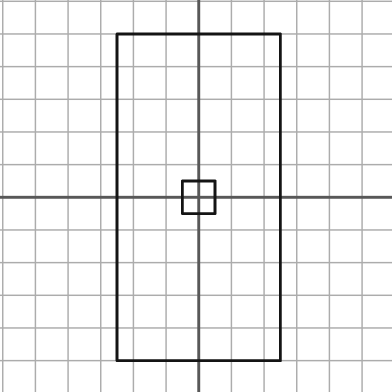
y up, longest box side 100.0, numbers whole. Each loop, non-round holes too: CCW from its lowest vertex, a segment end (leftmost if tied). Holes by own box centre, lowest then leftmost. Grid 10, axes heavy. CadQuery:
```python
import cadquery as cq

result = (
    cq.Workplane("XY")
    .moveTo(-25.0, -50.0)
    .lineTo(25.0, -50.0)
    .lineTo(25.0, 50.0)
    .lineTo(-25.0, 50.0)
    .close()
    .moveTo(-5.0, -5.0)
    .lineTo(5.0, -5.0)
    .lineTo(5.0, 5.0)
    .lineTo(-5.0, 5.0)
    .close()
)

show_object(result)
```